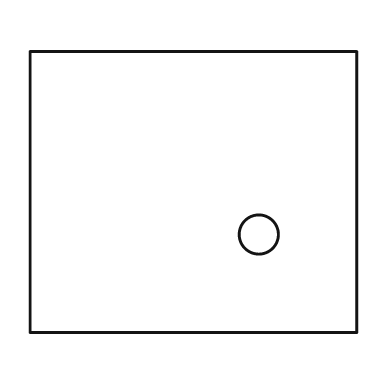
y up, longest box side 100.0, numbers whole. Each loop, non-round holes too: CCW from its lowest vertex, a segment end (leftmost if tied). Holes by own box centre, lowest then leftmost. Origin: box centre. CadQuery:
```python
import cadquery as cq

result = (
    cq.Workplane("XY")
    .moveTo(-50.0, -43.0)
    .lineTo(50.0, -43.0)
    .lineTo(50.0, 43.0)
    .lineTo(-50.0, 43.0)
    .close()
    .moveTo(20.0, -13.0)
    .circle(6.0)
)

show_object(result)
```